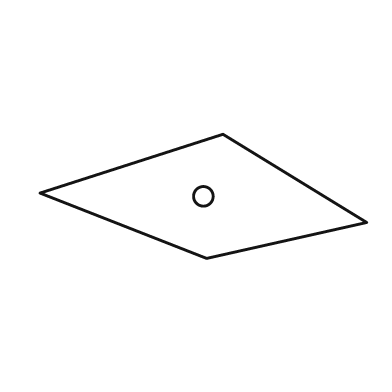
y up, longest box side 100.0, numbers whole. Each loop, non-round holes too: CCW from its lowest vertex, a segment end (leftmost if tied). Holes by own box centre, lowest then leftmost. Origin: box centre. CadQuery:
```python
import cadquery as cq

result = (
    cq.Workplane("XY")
    .moveTo(1.0, -19.0)
    .lineTo(50.0, -8.0)
    .lineTo(6.0, 19.0)
    .lineTo(-50.0, 1.0)
    .close()
    .moveTo(0.0, 0.0)
    .circle(3.0)
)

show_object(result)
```